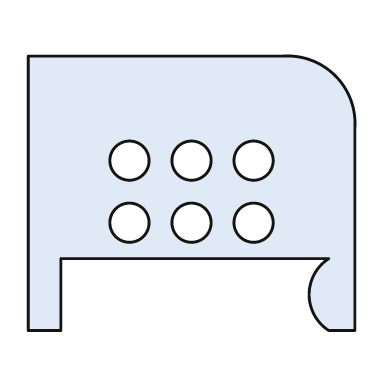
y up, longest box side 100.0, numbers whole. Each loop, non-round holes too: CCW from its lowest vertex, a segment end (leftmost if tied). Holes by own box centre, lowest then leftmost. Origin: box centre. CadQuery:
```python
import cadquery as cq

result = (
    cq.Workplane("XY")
    .moveTo(-50.0, -42.0)
    .lineTo(-40.0, -42.0)
    .lineTo(-40.0, -20.0)
    .lineTo(42.0, -20.0)
    .threePointArc((36.0, -31.0), (42.0, -42.0))
    .lineTo(50.0, -42.0)
    .lineTo(50.0, 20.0)
    .threePointArc((44.0, 36.0), (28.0, 42.0))
    .lineTo(-50.0, 42.0)
    .close()
    .moveTo(-19.0, -9.0)
    .circle(6.0)
    .moveTo(0.0, -9.0)
    .circle(6.0)
    .moveTo(19.0, -9.0)
    .circle(6.0)
    .moveTo(-19.0, 10.0)
    .circle(6.0)
    .moveTo(0.0, 10.0)
    .circle(6.0)
    .moveTo(19.0, 10.0)
    .circle(6.0)
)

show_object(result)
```